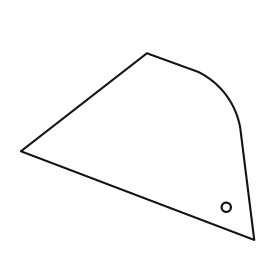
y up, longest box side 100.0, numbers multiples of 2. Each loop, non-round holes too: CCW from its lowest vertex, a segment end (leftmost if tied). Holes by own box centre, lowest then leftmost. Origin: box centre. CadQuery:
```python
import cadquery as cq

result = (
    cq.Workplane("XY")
    .moveTo(50.0, -40.0)
    .lineTo(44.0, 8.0)
    .threePointArc((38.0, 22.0), (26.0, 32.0))
    .lineTo(4.0, 40.0)
    .lineTo(-50.0, -2.0)
    .close()
    .moveTo(38.0, -26.0)
    .circle(2.0)
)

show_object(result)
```